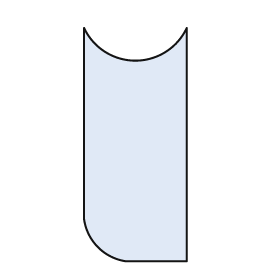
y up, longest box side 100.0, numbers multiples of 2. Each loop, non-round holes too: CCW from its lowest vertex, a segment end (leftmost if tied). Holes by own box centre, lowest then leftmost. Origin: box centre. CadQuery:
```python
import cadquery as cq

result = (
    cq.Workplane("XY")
    .moveTo(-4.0, -50.0)
    .lineTo(22.0, -50.0)
    .lineTo(22.0, 50.0)
    .threePointArc((0.0, 36.0), (-22.0, 50.0))
    .lineTo(-22.0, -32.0)
    .threePointArc((-16.0, -44.0), (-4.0, -50.0))
    .close()
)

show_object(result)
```